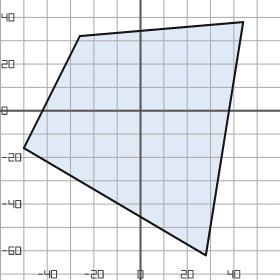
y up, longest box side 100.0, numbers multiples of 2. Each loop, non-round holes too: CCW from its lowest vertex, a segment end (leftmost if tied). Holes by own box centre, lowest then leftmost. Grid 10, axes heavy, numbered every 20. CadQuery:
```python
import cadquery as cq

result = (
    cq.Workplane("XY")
    .moveTo(28.0, -62.0)
    .lineTo(44.0, 38.0)
    .lineTo(-26.0, 32.0)
    .lineTo(-50.0, -16.0)
    .close()
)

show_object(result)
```